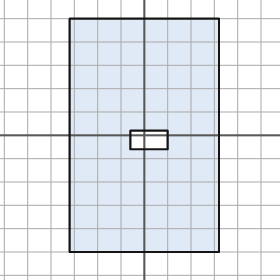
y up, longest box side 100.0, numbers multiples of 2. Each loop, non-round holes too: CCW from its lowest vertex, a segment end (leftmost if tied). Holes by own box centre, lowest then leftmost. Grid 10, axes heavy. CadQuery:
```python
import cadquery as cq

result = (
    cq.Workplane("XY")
    .moveTo(-32.0, -50.0)
    .lineTo(32.0, -50.0)
    .lineTo(32.0, 50.0)
    .lineTo(-32.0, 50.0)
    .close()
    .moveTo(-6.0, -6.0)
    .lineTo(10.0, -6.0)
    .lineTo(10.0, 2.0)
    .lineTo(-6.0, 2.0)
    .close()
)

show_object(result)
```